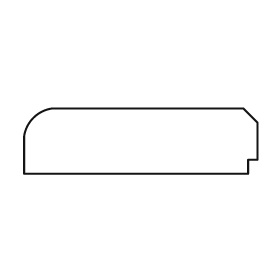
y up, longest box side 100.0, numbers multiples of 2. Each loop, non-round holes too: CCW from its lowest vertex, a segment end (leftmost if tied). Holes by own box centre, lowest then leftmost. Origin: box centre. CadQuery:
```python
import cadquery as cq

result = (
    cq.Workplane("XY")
    .moveTo(-50.0, -14.0)
    .lineTo(46.0, -14.0)
    .lineTo(46.0, -8.0)
    .lineTo(50.0, -8.0)
    .lineTo(50.0, 8.0)
    .lineTo(44.0, 14.0)
    .lineTo(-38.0, 14.0)
    .threePointArc((-46.0, 10.0), (-50.0, 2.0))
    .close()
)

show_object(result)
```